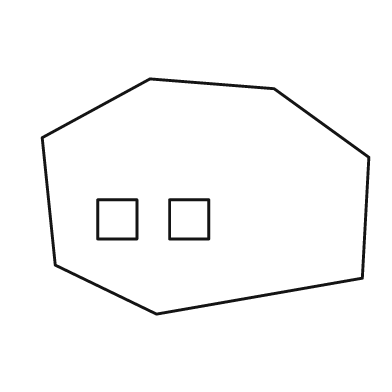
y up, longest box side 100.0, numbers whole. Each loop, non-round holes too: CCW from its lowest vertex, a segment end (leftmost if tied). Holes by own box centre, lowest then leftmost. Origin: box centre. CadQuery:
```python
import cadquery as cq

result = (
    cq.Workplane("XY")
    .moveTo(-15.0, -36.0)
    .lineTo(48.0, -25.0)
    .lineTo(50.0, 12.0)
    .lineTo(21.0, 33.0)
    .lineTo(-17.0, 36.0)
    .lineTo(-50.0, 18.0)
    .lineTo(-46.0, -21.0)
    .close()
    .moveTo(-33.0, -13.0)
    .lineTo(-21.0, -13.0)
    .lineTo(-21.0, -1.0)
    .lineTo(-33.0, -1.0)
    .close()
    .moveTo(-11.0, -13.0)
    .lineTo(1.0, -13.0)
    .lineTo(1.0, -1.0)
    .lineTo(-11.0, -1.0)
    .close()
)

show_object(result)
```